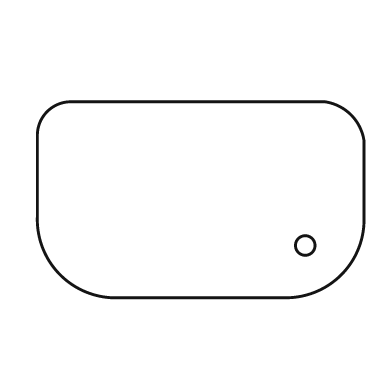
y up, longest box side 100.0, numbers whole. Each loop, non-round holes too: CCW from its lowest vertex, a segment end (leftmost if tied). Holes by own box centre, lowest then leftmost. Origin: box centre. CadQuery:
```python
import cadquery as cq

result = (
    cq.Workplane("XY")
    .moveTo(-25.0, -30.0)
    .lineTo(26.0, -30.0)
    .threePointArc((43.0, -23.0), (50.0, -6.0))
    .lineTo(50.0, 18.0)
    .threePointArc((46.0, 26.0), (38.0, 30.0))
    .lineTo(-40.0, 30.0)
    .threePointArc((-47.0, 27.0), (-50.0, 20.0))
    .lineTo(-50.0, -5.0)
    .threePointArc((-43.0, -23.0), (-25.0, -30.0))
    .close()
    .moveTo(32.0, -14.0)
    .circle(3.0)
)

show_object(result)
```